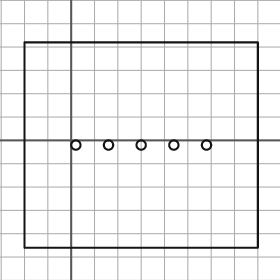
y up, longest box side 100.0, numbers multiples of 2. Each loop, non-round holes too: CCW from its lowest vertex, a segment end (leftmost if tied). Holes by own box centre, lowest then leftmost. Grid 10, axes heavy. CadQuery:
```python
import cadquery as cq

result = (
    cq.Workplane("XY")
    .moveTo(-20.0, -46.0)
    .lineTo(80.0, -46.0)
    .lineTo(80.0, 42.0)
    .lineTo(-20.0, 42.0)
    .close()
    .moveTo(2.0, -2.0)
    .circle(2.0)
    .moveTo(16.0, -2.0)
    .circle(2.0)
    .moveTo(30.0, -2.0)
    .circle(2.0)
    .moveTo(44.0, -2.0)
    .circle(2.0)
    .moveTo(58.0, -2.0)
    .circle(2.0)
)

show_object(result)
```